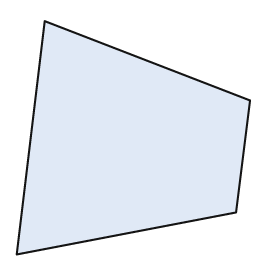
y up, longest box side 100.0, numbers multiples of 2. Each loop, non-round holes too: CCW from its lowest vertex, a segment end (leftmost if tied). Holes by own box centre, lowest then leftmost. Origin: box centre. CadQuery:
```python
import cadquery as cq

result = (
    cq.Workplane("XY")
    .moveTo(-50.0, -50.0)
    .lineTo(44.0, -32.0)
    .lineTo(50.0, 16.0)
    .lineTo(-38.0, 50.0)
    .close()
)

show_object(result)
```